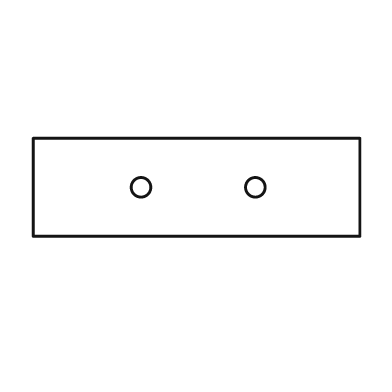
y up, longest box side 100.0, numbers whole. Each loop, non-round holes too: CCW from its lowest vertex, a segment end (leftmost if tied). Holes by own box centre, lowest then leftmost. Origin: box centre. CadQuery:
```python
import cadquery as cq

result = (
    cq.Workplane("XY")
    .moveTo(-50.0, -15.0)
    .lineTo(50.0, -15.0)
    .lineTo(50.0, 15.0)
    .lineTo(-50.0, 15.0)
    .close()
    .moveTo(-17.0, 0.0)
    .circle(3.0)
    .moveTo(18.0, 0.0)
    .circle(3.0)
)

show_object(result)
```